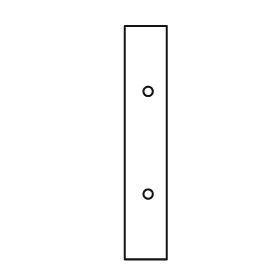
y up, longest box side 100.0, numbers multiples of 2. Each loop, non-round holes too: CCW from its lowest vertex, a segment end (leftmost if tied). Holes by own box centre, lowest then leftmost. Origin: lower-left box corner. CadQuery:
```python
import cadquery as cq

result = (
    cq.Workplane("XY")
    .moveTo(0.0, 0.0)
    .lineTo(18.0, 0.0)
    .lineTo(18.0, 100.0)
    .lineTo(0.0, 100.0)
    .close()
    .moveTo(10.0, 28.0)
    .circle(2.0)
    .moveTo(10.0, 72.0)
    .circle(2.0)
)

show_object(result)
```